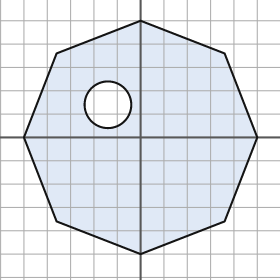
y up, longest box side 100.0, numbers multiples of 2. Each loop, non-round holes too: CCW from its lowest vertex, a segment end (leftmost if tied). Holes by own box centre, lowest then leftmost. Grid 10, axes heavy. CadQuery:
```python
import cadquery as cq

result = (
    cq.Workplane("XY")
    .moveTo(0.0, -50.0)
    .lineTo(36.0, -36.0)
    .lineTo(50.0, 0.0)
    .lineTo(36.0, 36.0)
    .lineTo(0.0, 50.0)
    .lineTo(-36.0, 36.0)
    .lineTo(-50.0, 0.0)
    .lineTo(-36.0, -36.0)
    .close()
    .moveTo(-14.0, 14.0)
    .circle(10.0)
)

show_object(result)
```